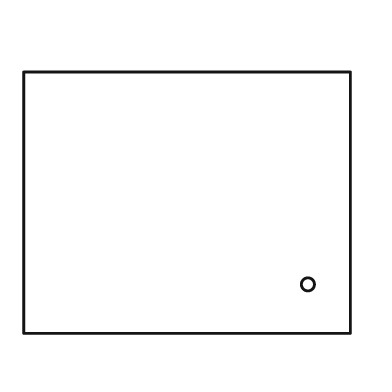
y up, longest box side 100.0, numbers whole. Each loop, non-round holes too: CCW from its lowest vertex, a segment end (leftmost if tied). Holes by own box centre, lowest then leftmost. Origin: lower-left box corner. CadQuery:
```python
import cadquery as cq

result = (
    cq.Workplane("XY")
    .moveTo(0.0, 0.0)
    .lineTo(100.0, 0.0)
    .lineTo(100.0, 80.0)
    .lineTo(0.0, 80.0)
    .close()
    .moveTo(87.0, 15.0)
    .circle(2.0)
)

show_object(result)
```